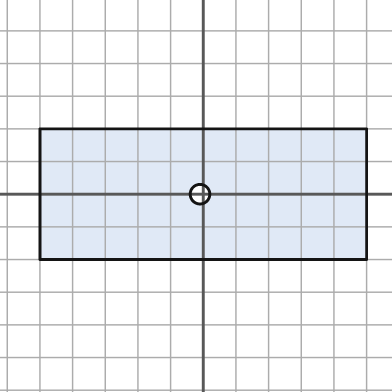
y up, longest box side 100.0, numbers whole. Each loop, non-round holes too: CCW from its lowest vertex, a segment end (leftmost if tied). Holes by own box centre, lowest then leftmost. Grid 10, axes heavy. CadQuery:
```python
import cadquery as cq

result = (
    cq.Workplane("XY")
    .moveTo(-50.0, -20.0)
    .lineTo(50.0, -20.0)
    .lineTo(50.0, 20.0)
    .lineTo(-50.0, 20.0)
    .close()
    .moveTo(-1.0, 0.0)
    .circle(3.0)
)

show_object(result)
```